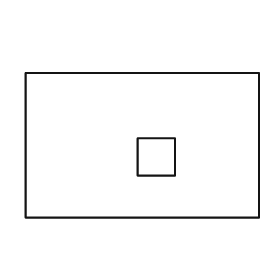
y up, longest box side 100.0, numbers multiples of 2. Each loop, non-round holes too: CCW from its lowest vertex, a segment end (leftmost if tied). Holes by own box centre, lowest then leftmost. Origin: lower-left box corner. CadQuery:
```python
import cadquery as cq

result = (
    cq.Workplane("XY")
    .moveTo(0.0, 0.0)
    .lineTo(100.0, 0.0)
    .lineTo(100.0, 62.0)
    .lineTo(0.0, 62.0)
    .close()
    .moveTo(48.0, 18.0)
    .lineTo(64.0, 18.0)
    .lineTo(64.0, 34.0)
    .lineTo(48.0, 34.0)
    .close()
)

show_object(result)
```